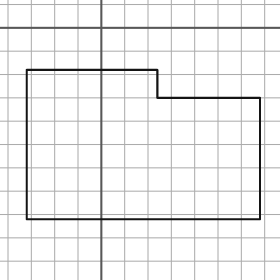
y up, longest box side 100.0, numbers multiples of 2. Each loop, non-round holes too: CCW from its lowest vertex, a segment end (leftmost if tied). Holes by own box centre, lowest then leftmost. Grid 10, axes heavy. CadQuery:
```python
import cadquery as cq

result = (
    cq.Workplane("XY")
    .moveTo(-32.0, -82.0)
    .lineTo(68.0, -82.0)
    .lineTo(68.0, -30.0)
    .lineTo(24.0, -30.0)
    .lineTo(24.0, -18.0)
    .lineTo(-32.0, -18.0)
    .close()
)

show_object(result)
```